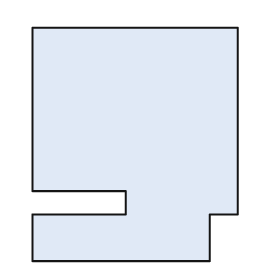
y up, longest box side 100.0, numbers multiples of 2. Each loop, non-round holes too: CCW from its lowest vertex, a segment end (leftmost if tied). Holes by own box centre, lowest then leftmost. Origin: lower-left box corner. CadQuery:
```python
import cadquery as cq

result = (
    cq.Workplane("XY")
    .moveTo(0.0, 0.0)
    .lineTo(76.0, 0.0)
    .lineTo(76.0, 20.0)
    .lineTo(88.0, 20.0)
    .lineTo(88.0, 100.0)
    .lineTo(0.0, 100.0)
    .lineTo(0.0, 30.0)
    .lineTo(40.0, 30.0)
    .lineTo(40.0, 20.0)
    .lineTo(0.0, 20.0)
    .close()
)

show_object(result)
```